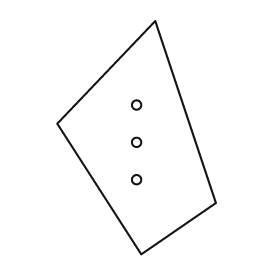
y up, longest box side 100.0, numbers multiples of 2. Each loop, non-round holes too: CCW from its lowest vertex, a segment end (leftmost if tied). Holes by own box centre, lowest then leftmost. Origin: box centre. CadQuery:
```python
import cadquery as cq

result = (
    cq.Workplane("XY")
    .moveTo(2.0, -50.0)
    .lineTo(34.0, -28.0)
    .lineTo(8.0, 50.0)
    .lineTo(-34.0, 6.0)
    .close()
    .moveTo(0.0, -18.0)
    .circle(2.0)
    .moveTo(0.0, -2.0)
    .circle(2.0)
    .moveTo(0.0, 14.0)
    .circle(2.0)
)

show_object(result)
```